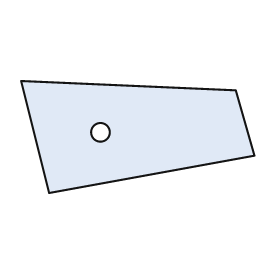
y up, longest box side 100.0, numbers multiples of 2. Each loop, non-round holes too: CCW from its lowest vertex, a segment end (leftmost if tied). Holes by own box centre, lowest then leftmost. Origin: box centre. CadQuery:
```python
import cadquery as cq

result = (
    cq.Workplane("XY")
    .moveTo(-38.0, -24.0)
    .lineTo(50.0, -8.0)
    .lineTo(42.0, 20.0)
    .lineTo(-50.0, 24.0)
    .close()
    .moveTo(-16.0, 2.0)
    .circle(4.0)
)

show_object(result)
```